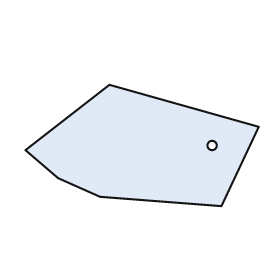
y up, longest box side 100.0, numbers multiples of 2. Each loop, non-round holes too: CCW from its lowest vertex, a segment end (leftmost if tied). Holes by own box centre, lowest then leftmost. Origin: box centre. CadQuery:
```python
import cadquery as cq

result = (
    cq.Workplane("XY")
    .moveTo(34.0, -26.0)
    .lineTo(50.0, 8.0)
    .lineTo(-14.0, 26.0)
    .lineTo(-50.0, -2.0)
    .lineTo(-36.0, -14.0)
    .lineTo(-18.0, -22.0)
    .close()
    .moveTo(30.0, 0.0)
    .circle(2.0)
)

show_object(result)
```